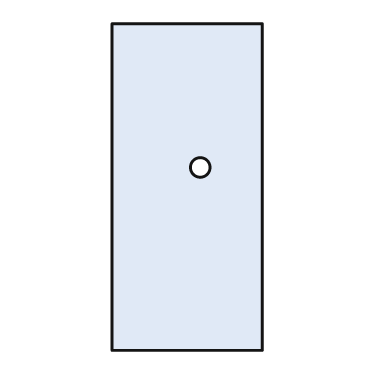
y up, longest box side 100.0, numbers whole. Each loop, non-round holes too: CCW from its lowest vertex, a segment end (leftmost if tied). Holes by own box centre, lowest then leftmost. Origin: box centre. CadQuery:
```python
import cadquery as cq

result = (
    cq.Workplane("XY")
    .moveTo(-23.0, -50.0)
    .lineTo(23.0, -50.0)
    .lineTo(23.0, 50.0)
    .lineTo(-23.0, 50.0)
    .close()
    .moveTo(4.0, 6.0)
    .circle(3.0)
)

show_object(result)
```